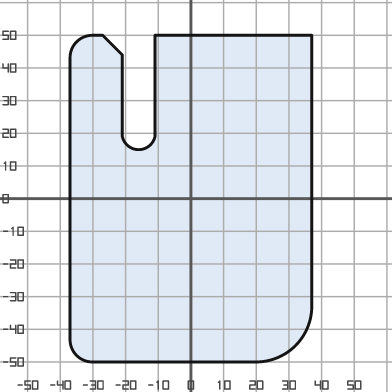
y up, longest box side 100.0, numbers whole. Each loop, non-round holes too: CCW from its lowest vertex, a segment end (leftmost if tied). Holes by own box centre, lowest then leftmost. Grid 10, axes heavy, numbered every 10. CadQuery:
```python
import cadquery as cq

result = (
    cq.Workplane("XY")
    .moveTo(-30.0, -50.0)
    .lineTo(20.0, -50.0)
    .threePointArc((32.0, -45.0), (37.0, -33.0))
    .lineTo(37.0, 50.0)
    .lineTo(-11.0, 50.0)
    .lineTo(-11.0, 19.0)
    .threePointArc((-16.0, 15.0), (-21.0, 19.0))
    .lineTo(-21.0, 44.0)
    .lineTo(-27.0, 50.0)
    .lineTo(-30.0, 50.0)
    .threePointArc((-35.0, 48.0), (-37.0, 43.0))
    .lineTo(-37.0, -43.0)
    .threePointArc((-35.0, -48.0), (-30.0, -50.0))
    .close()
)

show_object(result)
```